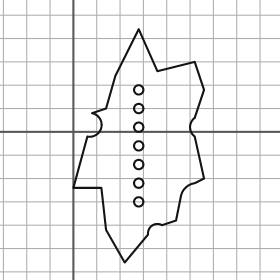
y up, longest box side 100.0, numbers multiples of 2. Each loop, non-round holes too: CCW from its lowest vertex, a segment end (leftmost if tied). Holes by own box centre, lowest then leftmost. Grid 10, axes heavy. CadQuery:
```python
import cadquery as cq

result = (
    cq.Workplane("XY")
    .moveTo(22.0, -56.0)
    .lineTo(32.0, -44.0)
    .threePointArc((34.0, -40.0), (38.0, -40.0))
    .lineTo(44.0, -38.0)
    .lineTo(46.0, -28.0)
    .threePointArc((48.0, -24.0), (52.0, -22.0))
    .lineTo(56.0, -20.0)
    .lineTo(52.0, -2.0)
    .threePointArc((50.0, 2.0), (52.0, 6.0))
    .lineTo(56.0, 18.0)
    .lineTo(52.0, 30.0)
    .lineTo(36.0, 26.0)
    .lineTo(28.0, 44.0)
    .lineTo(18.0, 24.0)
    .lineTo(14.0, 10.0)
    .lineTo(8.0, 8.0)
    .threePointArc((12.0, 2.0), (6.0, -2.0))
    .lineTo(0.0, -24.0)
    .lineTo(12.0, -24.0)
    .lineTo(14.0, -42.0)
    .close()
    .moveTo(28.0, -30.0)
    .circle(2.0)
    .moveTo(28.0, -22.0)
    .circle(2.0)
    .moveTo(28.0, -14.0)
    .circle(2.0)
    .moveTo(28.0, -6.0)
    .circle(2.0)
    .moveTo(28.0, 2.0)
    .circle(2.0)
    .moveTo(28.0, 10.0)
    .circle(2.0)
    .moveTo(28.0, 18.0)
    .circle(2.0)
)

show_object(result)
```